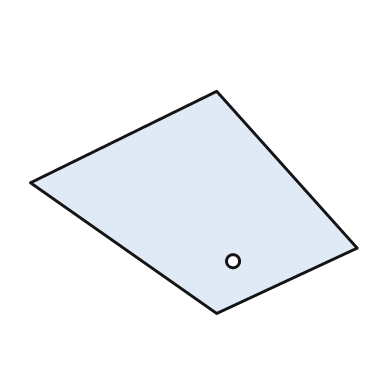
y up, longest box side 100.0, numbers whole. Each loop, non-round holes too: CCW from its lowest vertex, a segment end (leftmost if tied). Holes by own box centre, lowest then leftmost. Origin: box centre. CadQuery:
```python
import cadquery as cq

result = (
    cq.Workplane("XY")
    .moveTo(7.0, -34.0)
    .lineTo(50.0, -14.0)
    .lineTo(7.0, 34.0)
    .lineTo(-50.0, 6.0)
    .close()
    .moveTo(12.0, -18.0)
    .circle(2.0)
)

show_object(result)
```